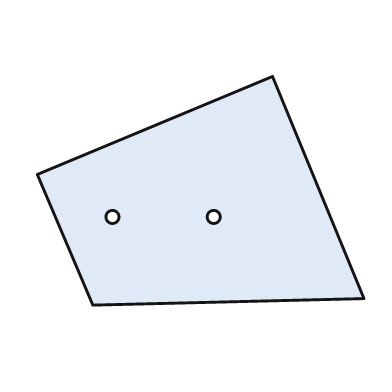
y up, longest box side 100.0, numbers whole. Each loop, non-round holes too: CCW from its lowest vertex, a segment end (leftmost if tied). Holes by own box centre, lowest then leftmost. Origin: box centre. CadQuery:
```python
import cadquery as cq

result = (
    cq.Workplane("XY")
    .moveTo(-33.0, -35.0)
    .lineTo(50.0, -33.0)
    .lineTo(22.0, 35.0)
    .lineTo(-50.0, 5.0)
    .close()
    .moveTo(-27.0, -8.0)
    .circle(2.0)
    .moveTo(4.0, -8.0)
    .circle(2.0)
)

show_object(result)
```